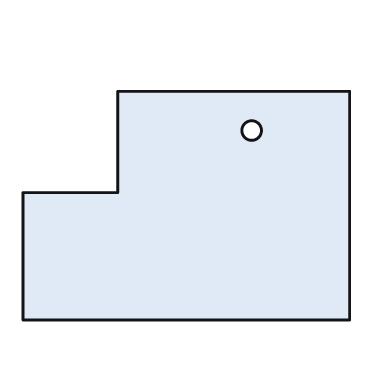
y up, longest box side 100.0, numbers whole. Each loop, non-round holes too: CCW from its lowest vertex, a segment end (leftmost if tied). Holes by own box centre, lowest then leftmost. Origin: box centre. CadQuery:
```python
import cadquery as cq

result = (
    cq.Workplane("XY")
    .moveTo(-50.0, -35.0)
    .lineTo(50.0, -35.0)
    .lineTo(50.0, 35.0)
    .lineTo(-21.0, 35.0)
    .lineTo(-21.0, 4.0)
    .lineTo(-50.0, 4.0)
    .close()
    .moveTo(20.0, 23.0)
    .circle(3.0)
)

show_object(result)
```